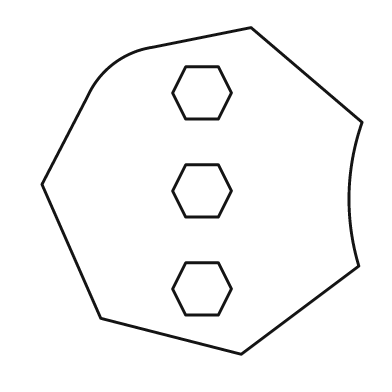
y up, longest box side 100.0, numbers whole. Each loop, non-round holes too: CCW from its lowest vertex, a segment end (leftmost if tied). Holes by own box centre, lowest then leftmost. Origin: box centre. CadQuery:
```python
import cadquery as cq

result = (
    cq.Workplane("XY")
    .moveTo(12.0, -50.0)
    .lineTo(48.0, -23.0)
    .threePointArc((45.0, -1.0), (49.0, 21.0))
    .lineTo(15.0, 50.0)
    .lineTo(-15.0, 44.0)
    .threePointArc((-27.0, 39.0), (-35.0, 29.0))
    .lineTo(-49.0, 2.0)
    .lineTo(-31.0, -39.0)
    .close()
    .moveTo(-5.0, -38.0)
    .lineTo(5.0, -38.0)
    .lineTo(9.0, -30.0)
    .lineTo(5.0, -22.0)
    .lineTo(-5.0, -22.0)
    .lineTo(-9.0, -30.0)
    .close()
    .moveTo(-5.0, -8.0)
    .lineTo(5.0, -8.0)
    .lineTo(9.0, 0.0)
    .lineTo(5.0, 8.0)
    .lineTo(-5.0, 8.0)
    .lineTo(-9.0, 0.0)
    .close()
    .moveTo(-5.0, 22.0)
    .lineTo(5.0, 22.0)
    .lineTo(9.0, 30.0)
    .lineTo(5.0, 38.0)
    .lineTo(-5.0, 38.0)
    .lineTo(-9.0, 30.0)
    .close()
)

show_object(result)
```